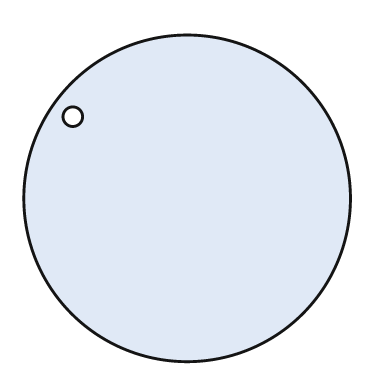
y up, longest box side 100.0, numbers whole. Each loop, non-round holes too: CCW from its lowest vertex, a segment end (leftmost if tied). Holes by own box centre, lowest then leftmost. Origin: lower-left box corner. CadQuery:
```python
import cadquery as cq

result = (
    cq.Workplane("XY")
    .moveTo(50.0, 50.0)
    .circle(50.0)
    .moveTo(15.0, 75.0)
    .circle(3.0)
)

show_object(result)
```